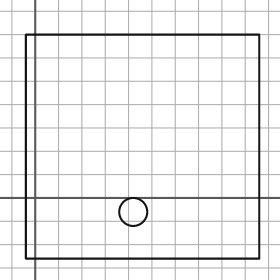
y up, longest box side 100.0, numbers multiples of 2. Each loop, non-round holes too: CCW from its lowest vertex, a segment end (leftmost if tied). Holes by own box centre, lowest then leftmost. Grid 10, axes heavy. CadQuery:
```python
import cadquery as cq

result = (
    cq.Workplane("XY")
    .moveTo(-4.0, -26.0)
    .lineTo(96.0, -26.0)
    .lineTo(96.0, 70.0)
    .lineTo(-4.0, 70.0)
    .close()
    .moveTo(42.0, -6.0)
    .circle(6.0)
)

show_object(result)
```